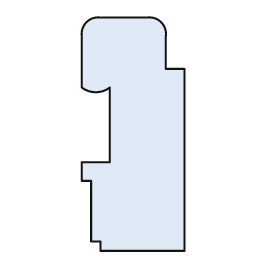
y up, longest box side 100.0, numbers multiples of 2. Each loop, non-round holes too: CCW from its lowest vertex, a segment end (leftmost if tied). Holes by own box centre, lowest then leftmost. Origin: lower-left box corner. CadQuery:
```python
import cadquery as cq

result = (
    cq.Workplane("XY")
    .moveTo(8.0, 0.0)
    .lineTo(44.0, 0.0)
    .lineTo(44.0, 78.0)
    .lineTo(36.0, 78.0)
    .lineTo(36.0, 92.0)
    .threePointArc((34.0, 98.0), (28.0, 100.0))
    .lineTo(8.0, 100.0)
    .threePointArc((2.0, 98.0), (0.0, 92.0))
    .lineTo(0.0, 70.0)
    .threePointArc((6.0, 68.0), (12.0, 70.0))
    .lineTo(12.0, 38.0)
    .lineTo(0.0, 38.0)
    .lineTo(0.0, 30.0)
    .lineTo(4.0, 30.0)
    .lineTo(4.0, 4.0)
    .lineTo(8.0, 4.0)
    .close()
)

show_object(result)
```